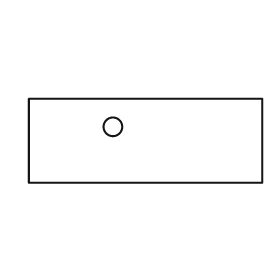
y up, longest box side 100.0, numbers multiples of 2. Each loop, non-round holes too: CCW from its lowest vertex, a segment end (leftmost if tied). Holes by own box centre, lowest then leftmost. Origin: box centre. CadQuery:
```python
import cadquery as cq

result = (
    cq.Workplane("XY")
    .moveTo(-50.0, -18.0)
    .lineTo(50.0, -18.0)
    .lineTo(50.0, 18.0)
    .lineTo(-50.0, 18.0)
    .close()
    .moveTo(-14.0, 6.0)
    .circle(4.0)
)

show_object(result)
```